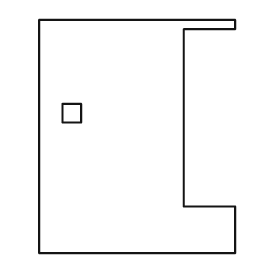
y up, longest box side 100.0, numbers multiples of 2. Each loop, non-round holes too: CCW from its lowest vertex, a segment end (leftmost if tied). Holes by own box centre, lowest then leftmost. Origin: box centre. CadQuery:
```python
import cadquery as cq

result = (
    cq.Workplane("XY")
    .moveTo(-42.0, -50.0)
    .lineTo(42.0, -50.0)
    .lineTo(42.0, -30.0)
    .lineTo(20.0, -30.0)
    .lineTo(20.0, 46.0)
    .lineTo(42.0, 46.0)
    .lineTo(42.0, 50.0)
    .lineTo(-42.0, 50.0)
    .close()
    .moveTo(-32.0, 6.0)
    .lineTo(-24.0, 6.0)
    .lineTo(-24.0, 14.0)
    .lineTo(-32.0, 14.0)
    .close()
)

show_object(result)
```